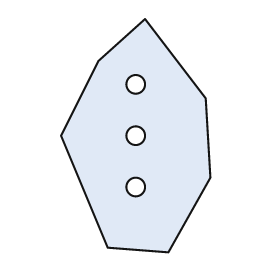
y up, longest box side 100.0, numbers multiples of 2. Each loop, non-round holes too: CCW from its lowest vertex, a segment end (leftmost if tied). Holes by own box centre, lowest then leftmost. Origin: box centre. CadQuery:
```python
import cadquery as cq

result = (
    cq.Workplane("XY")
    .moveTo(14.0, -50.0)
    .lineTo(32.0, -18.0)
    .lineTo(30.0, 16.0)
    .lineTo(4.0, 50.0)
    .lineTo(-16.0, 32.0)
    .lineTo(-32.0, 0.0)
    .lineTo(-12.0, -48.0)
    .close()
    .moveTo(0.0, -22.0)
    .circle(4.0)
    .moveTo(0.0, 0.0)
    .circle(4.0)
    .moveTo(0.0, 22.0)
    .circle(4.0)
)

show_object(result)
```